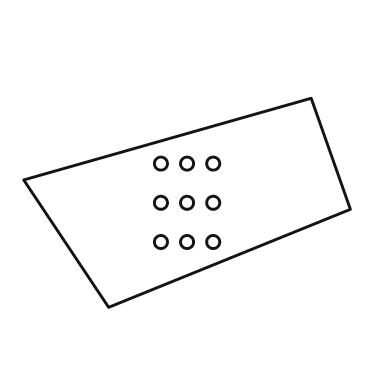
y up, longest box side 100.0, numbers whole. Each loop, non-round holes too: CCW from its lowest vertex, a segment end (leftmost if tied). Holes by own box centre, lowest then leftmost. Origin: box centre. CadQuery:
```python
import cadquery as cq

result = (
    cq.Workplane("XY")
    .moveTo(-24.0, -32.0)
    .lineTo(50.0, -2.0)
    .lineTo(38.0, 32.0)
    .lineTo(-50.0, 7.0)
    .close()
    .moveTo(-8.0, -12.0)
    .circle(2.0)
    .moveTo(0.0, -12.0)
    .circle(2.0)
    .moveTo(8.0, -12.0)
    .circle(2.0)
    .moveTo(-8.0, 0.0)
    .circle(2.0)
    .moveTo(0.0, 0.0)
    .circle(2.0)
    .moveTo(8.0, 0.0)
    .circle(2.0)
    .moveTo(-8.0, 12.0)
    .circle(2.0)
    .moveTo(0.0, 12.0)
    .circle(2.0)
    .moveTo(8.0, 12.0)
    .circle(2.0)
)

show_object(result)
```